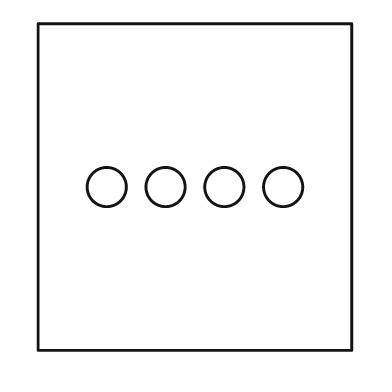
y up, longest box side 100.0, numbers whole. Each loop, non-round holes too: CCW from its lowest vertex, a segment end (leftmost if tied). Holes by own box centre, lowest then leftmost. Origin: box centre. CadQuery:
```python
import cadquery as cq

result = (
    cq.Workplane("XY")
    .moveTo(-48.0, -50.0)
    .lineTo(48.0, -50.0)
    .lineTo(48.0, 50.0)
    .lineTo(-48.0, 50.0)
    .close()
    .moveTo(-27.0, 0.0)
    .circle(6.0)
    .moveTo(-9.0, 0.0)
    .circle(6.0)
    .moveTo(9.0, 0.0)
    .circle(6.0)
    .moveTo(27.0, 0.0)
    .circle(6.0)
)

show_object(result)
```